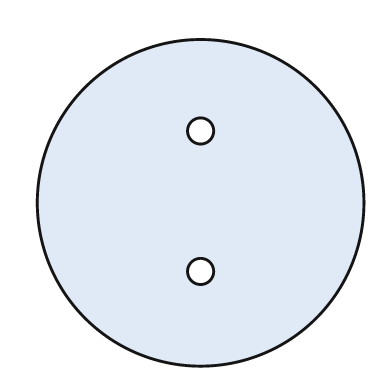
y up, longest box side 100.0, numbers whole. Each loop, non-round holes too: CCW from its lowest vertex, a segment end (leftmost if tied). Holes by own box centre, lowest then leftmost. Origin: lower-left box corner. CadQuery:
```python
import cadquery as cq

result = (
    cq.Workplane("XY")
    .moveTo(50.0, 50.0)
    .circle(50.0)
    .moveTo(50.0, 29.0)
    .circle(4.0)
    .moveTo(50.0, 72.0)
    .circle(4.0)
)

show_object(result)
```